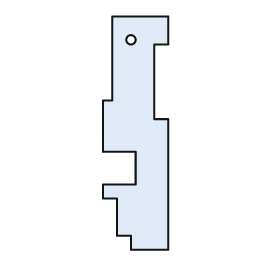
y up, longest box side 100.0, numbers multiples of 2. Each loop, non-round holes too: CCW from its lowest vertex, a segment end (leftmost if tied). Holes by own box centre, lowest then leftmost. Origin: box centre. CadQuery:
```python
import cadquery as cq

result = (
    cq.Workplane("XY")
    .moveTo(-2.0, -50.0)
    .lineTo(14.0, -50.0)
    .lineTo(14.0, 6.0)
    .lineTo(8.0, 6.0)
    .lineTo(8.0, 38.0)
    .lineTo(14.0, 38.0)
    .lineTo(14.0, 50.0)
    .lineTo(-10.0, 50.0)
    .lineTo(-10.0, 14.0)
    .lineTo(-14.0, 14.0)
    .lineTo(-14.0, -8.0)
    .lineTo(0.0, -8.0)
    .lineTo(0.0, -22.0)
    .lineTo(-14.0, -22.0)
    .lineTo(-14.0, -28.0)
    .lineTo(-8.0, -28.0)
    .lineTo(-8.0, -44.0)
    .lineTo(-2.0, -44.0)
    .close()
    .moveTo(-2.0, 40.0)
    .circle(2.0)
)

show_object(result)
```